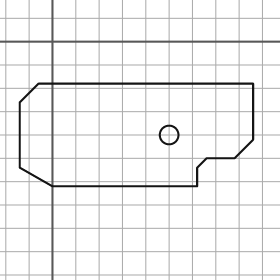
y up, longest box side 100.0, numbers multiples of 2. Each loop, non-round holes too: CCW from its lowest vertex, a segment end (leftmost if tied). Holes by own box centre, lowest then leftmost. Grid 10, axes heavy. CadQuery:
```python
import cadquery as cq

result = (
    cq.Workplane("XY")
    .moveTo(0.0, -62.0)
    .lineTo(62.0, -62.0)
    .lineTo(62.0, -54.0)
    .lineTo(66.0, -50.0)
    .lineTo(78.0, -50.0)
    .lineTo(86.0, -42.0)
    .lineTo(86.0, -18.0)
    .lineTo(-6.0, -18.0)
    .lineTo(-14.0, -26.0)
    .lineTo(-14.0, -54.0)
    .close()
    .moveTo(50.0, -40.0)
    .circle(4.0)
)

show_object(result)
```